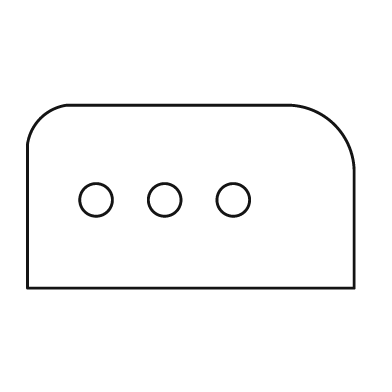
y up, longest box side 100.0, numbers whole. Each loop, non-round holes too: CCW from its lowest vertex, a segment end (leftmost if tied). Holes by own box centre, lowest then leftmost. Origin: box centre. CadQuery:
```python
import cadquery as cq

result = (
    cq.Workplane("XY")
    .moveTo(-50.0, -28.0)
    .lineTo(50.0, -28.0)
    .lineTo(50.0, 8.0)
    .threePointArc((44.0, 22.0), (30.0, 28.0))
    .lineTo(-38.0, 28.0)
    .threePointArc((-46.0, 24.0), (-50.0, 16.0))
    .close()
    .moveTo(-29.0, -1.0)
    .circle(5.0)
    .moveTo(-8.0, -1.0)
    .circle(5.0)
    .moveTo(13.0, -1.0)
    .circle(5.0)
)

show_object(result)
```